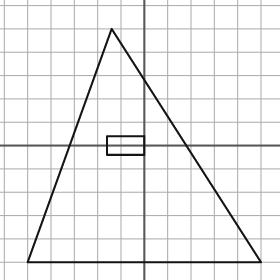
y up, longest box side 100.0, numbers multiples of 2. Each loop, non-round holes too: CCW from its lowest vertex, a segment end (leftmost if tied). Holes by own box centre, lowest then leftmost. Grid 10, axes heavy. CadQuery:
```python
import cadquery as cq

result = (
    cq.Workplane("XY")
    .moveTo(-50.0, -50.0)
    .lineTo(50.0, -50.0)
    .lineTo(-14.0, 50.0)
    .close()
    .moveTo(-16.0, -4.0)
    .lineTo(0.0, -4.0)
    .lineTo(0.0, 4.0)
    .lineTo(-16.0, 4.0)
    .close()
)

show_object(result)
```